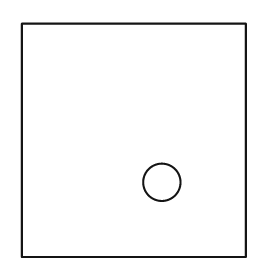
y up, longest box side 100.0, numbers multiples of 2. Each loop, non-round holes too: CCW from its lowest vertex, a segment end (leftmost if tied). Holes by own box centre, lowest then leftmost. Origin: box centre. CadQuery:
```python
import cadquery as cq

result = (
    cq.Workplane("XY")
    .moveTo(-48.0, -50.0)
    .lineTo(48.0, -50.0)
    .lineTo(48.0, 50.0)
    .lineTo(-48.0, 50.0)
    .close()
    .moveTo(12.0, -18.0)
    .circle(8.0)
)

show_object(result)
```